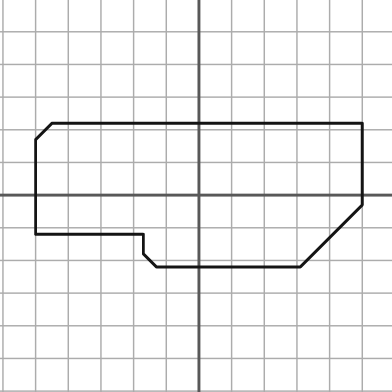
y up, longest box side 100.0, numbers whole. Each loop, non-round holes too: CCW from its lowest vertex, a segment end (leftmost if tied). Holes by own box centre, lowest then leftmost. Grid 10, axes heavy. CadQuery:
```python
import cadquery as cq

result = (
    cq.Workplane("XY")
    .moveTo(-13.0, -22.0)
    .lineTo(31.0, -22.0)
    .lineTo(50.0, -3.0)
    .lineTo(50.0, 22.0)
    .lineTo(-45.0, 22.0)
    .lineTo(-50.0, 17.0)
    .lineTo(-50.0, -12.0)
    .lineTo(-17.0, -12.0)
    .lineTo(-17.0, -18.0)
    .close()
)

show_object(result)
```